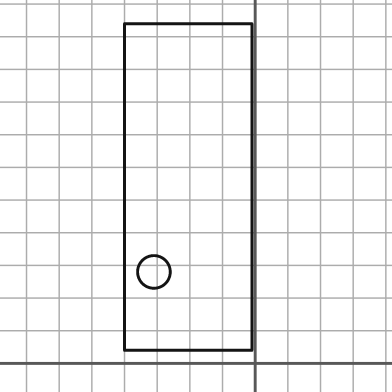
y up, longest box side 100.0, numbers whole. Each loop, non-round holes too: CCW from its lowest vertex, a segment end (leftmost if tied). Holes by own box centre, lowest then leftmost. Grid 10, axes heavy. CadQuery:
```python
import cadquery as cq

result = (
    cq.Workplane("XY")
    .moveTo(-40.0, 4.0)
    .lineTo(-1.0, 4.0)
    .lineTo(-1.0, 104.0)
    .lineTo(-40.0, 104.0)
    .close()
    .moveTo(-31.0, 28.0)
    .circle(5.0)
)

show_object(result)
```